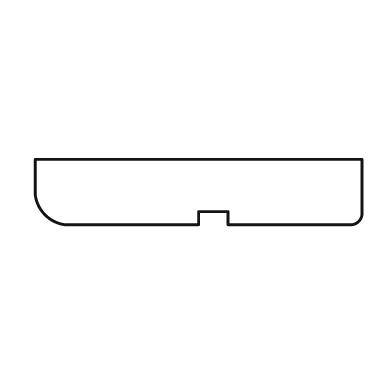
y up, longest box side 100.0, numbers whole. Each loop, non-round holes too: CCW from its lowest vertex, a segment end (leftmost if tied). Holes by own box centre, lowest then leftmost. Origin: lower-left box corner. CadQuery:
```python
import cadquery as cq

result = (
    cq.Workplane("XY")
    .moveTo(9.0, 0.0)
    .lineTo(50.0, 0.0)
    .lineTo(50.0, 4.0)
    .lineTo(59.0, 4.0)
    .lineTo(59.0, 0.0)
    .lineTo(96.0, 0.0)
    .threePointArc((99.0, 1.0), (100.0, 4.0))
    .lineTo(100.0, 20.0)
    .lineTo(0.0, 20.0)
    .lineTo(0.0, 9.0)
    .threePointArc((3.0, 3.0), (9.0, 0.0))
    .close()
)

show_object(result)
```